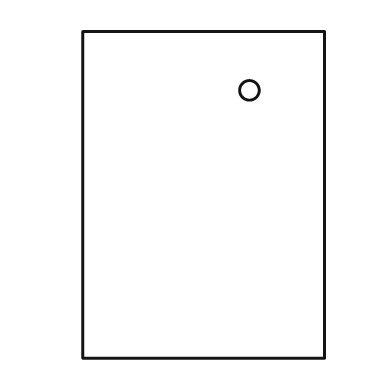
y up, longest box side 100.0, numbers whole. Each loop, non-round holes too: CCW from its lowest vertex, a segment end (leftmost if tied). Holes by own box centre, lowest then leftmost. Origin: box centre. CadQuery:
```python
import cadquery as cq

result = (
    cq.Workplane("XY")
    .moveTo(-37.0, -50.0)
    .lineTo(37.0, -50.0)
    .lineTo(37.0, 50.0)
    .lineTo(-37.0, 50.0)
    .close()
    .moveTo(14.0, 32.0)
    .circle(3.0)
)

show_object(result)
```